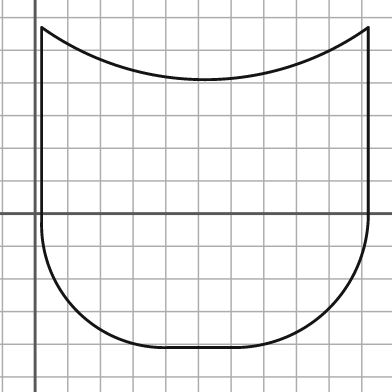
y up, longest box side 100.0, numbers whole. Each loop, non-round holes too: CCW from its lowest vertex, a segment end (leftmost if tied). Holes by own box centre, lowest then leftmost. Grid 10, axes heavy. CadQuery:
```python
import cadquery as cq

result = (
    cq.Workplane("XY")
    .moveTo(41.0, -41.0)
    .lineTo(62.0, -41.0)
    .threePointArc((90.0, -29.0), (102.0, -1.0))
    .lineTo(102.0, 57.0)
    .threePointArc((52.0, 41.0), (2.0, 57.0))
    .lineTo(2.0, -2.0)
    .threePointArc((13.0, -30.0), (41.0, -41.0))
    .close()
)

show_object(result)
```